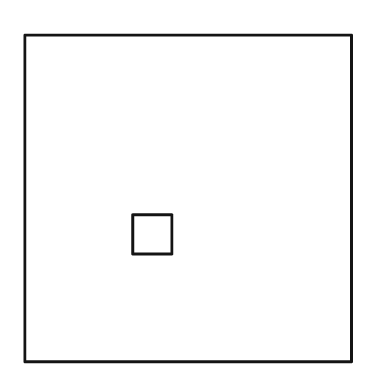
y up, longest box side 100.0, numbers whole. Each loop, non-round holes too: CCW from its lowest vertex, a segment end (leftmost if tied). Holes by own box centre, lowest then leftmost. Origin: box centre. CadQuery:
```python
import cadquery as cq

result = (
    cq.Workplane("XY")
    .moveTo(-50.0, -50.0)
    .lineTo(50.0, -50.0)
    .lineTo(50.0, 50.0)
    .lineTo(-50.0, 50.0)
    .close()
    .moveTo(-17.0, -17.0)
    .lineTo(-5.0, -17.0)
    .lineTo(-5.0, -5.0)
    .lineTo(-17.0, -5.0)
    .close()
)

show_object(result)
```